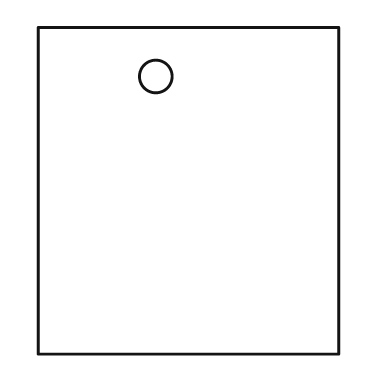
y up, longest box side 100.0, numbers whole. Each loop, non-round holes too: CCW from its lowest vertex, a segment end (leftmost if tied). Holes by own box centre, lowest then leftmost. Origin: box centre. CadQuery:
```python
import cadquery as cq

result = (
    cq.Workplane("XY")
    .moveTo(-46.0, -50.0)
    .lineTo(46.0, -50.0)
    .lineTo(46.0, 50.0)
    .lineTo(-46.0, 50.0)
    .close()
    .moveTo(-10.0, 35.0)
    .circle(5.0)
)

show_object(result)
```